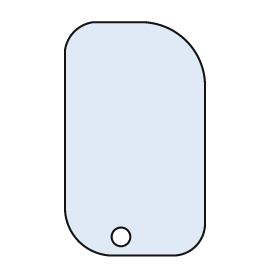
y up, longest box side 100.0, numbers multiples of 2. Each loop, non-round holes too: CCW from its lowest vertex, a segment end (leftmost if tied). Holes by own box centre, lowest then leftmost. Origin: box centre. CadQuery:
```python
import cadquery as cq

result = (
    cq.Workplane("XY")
    .moveTo(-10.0, -50.0)
    .lineTo(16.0, -50.0)
    .threePointArc((26.0, -46.0), (30.0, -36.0))
    .lineTo(30.0, 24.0)
    .threePointArc((22.0, 42.0), (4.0, 50.0))
    .lineTo(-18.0, 50.0)
    .threePointArc((-26.0, 46.0), (-30.0, 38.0))
    .lineTo(-30.0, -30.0)
    .threePointArc((-24.0, -44.0), (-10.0, -50.0))
    .close()
    .moveTo(-6.0, -42.0)
    .circle(4.0)
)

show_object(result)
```